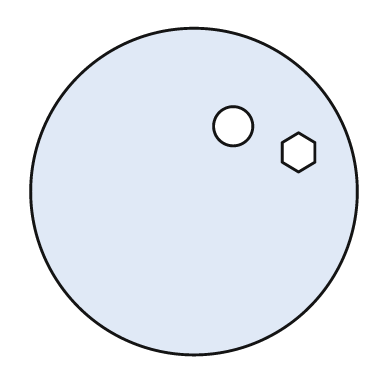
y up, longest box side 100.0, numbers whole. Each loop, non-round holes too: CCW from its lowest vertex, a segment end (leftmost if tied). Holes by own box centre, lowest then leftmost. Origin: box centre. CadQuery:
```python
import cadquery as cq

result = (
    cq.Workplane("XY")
    .moveTo(0.0, 0.0)
    .circle(50.0)
    .moveTo(32.0, 6.0)
    .lineTo(37.0, 9.0)
    .lineTo(37.0, 15.0)
    .lineTo(32.0, 18.0)
    .lineTo(27.0, 15.0)
    .lineTo(27.0, 9.0)
    .close()
    .moveTo(12.0, 20.0)
    .circle(6.0)
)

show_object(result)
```